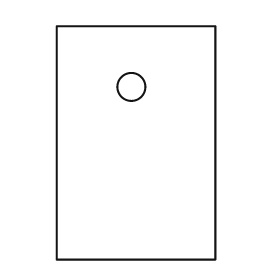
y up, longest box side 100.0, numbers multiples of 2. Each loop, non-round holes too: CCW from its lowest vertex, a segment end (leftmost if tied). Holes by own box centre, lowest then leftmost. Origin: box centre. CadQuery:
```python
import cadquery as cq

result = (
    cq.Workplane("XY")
    .moveTo(-34.0, -50.0)
    .lineTo(34.0, -50.0)
    .lineTo(34.0, 50.0)
    .lineTo(-34.0, 50.0)
    .close()
    .moveTo(-2.0, 24.0)
    .circle(6.0)
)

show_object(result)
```